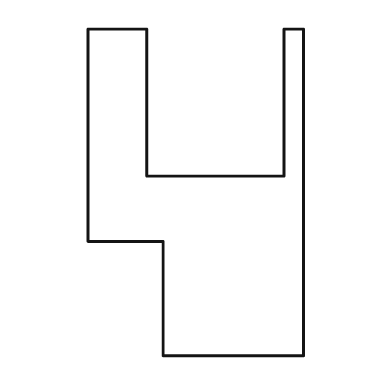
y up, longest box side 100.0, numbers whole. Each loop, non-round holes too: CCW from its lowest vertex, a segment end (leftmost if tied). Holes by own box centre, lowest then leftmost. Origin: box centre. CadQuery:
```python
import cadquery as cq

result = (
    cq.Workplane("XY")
    .moveTo(-10.0, -50.0)
    .lineTo(33.0, -50.0)
    .lineTo(33.0, 50.0)
    .lineTo(27.0, 50.0)
    .lineTo(27.0, 5.0)
    .lineTo(-15.0, 5.0)
    .lineTo(-15.0, 50.0)
    .lineTo(-33.0, 50.0)
    .lineTo(-33.0, -15.0)
    .lineTo(-10.0, -15.0)
    .close()
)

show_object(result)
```